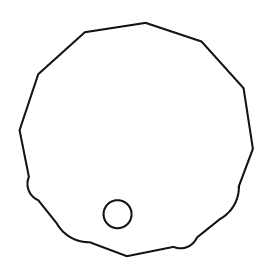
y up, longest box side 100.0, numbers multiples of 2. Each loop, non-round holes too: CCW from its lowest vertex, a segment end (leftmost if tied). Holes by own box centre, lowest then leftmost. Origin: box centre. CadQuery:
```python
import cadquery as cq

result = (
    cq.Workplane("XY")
    .moveTo(-4.0, -50.0)
    .lineTo(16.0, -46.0)
    .threePointArc((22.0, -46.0), (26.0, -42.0))
    .lineTo(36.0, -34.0)
    .threePointArc((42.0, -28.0), (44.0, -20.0))
    .lineTo(50.0, -4.0)
    .lineTo(46.0, 22.0)
    .lineTo(28.0, 42.0)
    .lineTo(4.0, 50.0)
    .lineTo(-22.0, 46.0)
    .lineTo(-42.0, 28.0)
    .lineTo(-50.0, 4.0)
    .lineTo(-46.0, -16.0)
    .threePointArc((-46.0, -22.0), (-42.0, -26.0))
    .lineTo(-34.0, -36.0)
    .threePointArc((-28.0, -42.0), (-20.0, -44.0))
    .close()
    .moveTo(-8.0, -32.0)
    .circle(6.0)
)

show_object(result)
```